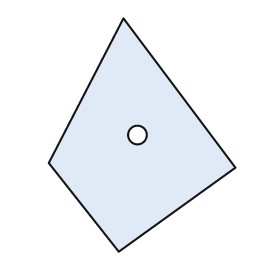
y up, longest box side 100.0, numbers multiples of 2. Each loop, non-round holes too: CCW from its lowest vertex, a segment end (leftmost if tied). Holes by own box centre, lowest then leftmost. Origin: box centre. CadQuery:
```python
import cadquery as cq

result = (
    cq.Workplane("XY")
    .moveTo(-10.0, -50.0)
    .lineTo(40.0, -14.0)
    .lineTo(-8.0, 50.0)
    .lineTo(-40.0, -12.0)
    .close()
    .moveTo(-2.0, 0.0)
    .circle(4.0)
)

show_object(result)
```